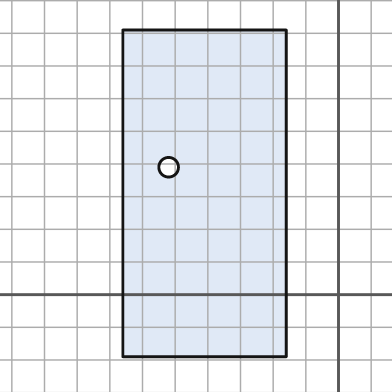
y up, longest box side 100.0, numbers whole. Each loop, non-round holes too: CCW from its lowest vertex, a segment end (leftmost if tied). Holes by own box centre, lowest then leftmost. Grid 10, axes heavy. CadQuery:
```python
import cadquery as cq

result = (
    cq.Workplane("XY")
    .moveTo(-66.0, -19.0)
    .lineTo(-16.0, -19.0)
    .lineTo(-16.0, 81.0)
    .lineTo(-66.0, 81.0)
    .close()
    .moveTo(-52.0, 39.0)
    .circle(3.0)
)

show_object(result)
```